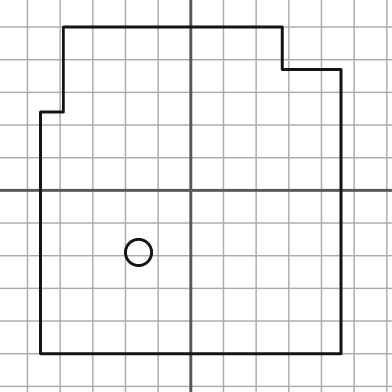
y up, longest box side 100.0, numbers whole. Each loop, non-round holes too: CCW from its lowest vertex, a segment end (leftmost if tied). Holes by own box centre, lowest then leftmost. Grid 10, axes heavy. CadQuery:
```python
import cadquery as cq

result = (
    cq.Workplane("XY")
    .moveTo(-46.0, -50.0)
    .lineTo(46.0, -50.0)
    .lineTo(46.0, 37.0)
    .lineTo(28.0, 37.0)
    .lineTo(28.0, 50.0)
    .lineTo(-39.0, 50.0)
    .lineTo(-39.0, 24.0)
    .lineTo(-46.0, 24.0)
    .close()
    .moveTo(-16.0, -19.0)
    .circle(4.0)
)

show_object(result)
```